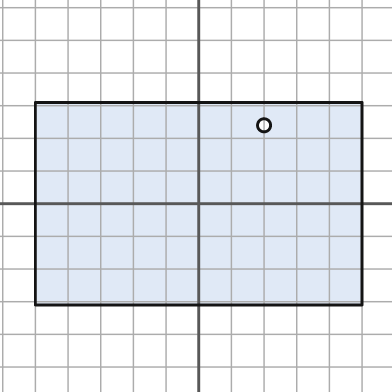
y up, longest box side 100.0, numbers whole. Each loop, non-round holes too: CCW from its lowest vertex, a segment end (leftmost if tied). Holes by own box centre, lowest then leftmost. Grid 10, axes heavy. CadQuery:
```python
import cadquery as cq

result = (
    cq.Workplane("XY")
    .moveTo(-50.0, -31.0)
    .lineTo(50.0, -31.0)
    .lineTo(50.0, 31.0)
    .lineTo(-50.0, 31.0)
    .close()
    .moveTo(20.0, 24.0)
    .circle(2.0)
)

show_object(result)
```